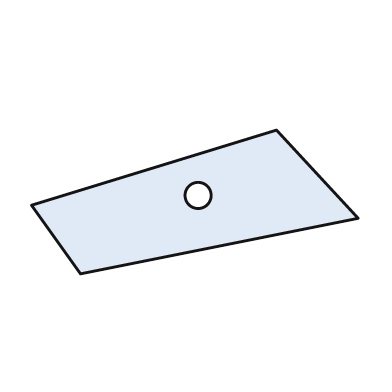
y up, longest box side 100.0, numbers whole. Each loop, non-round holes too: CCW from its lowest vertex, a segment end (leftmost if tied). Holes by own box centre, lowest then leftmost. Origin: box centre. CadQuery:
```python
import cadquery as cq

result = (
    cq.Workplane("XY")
    .moveTo(-35.0, -22.0)
    .lineTo(50.0, -5.0)
    .lineTo(25.0, 22.0)
    .lineTo(-50.0, -1.0)
    .close()
    .moveTo(1.0, 2.0)
    .circle(4.0)
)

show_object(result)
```